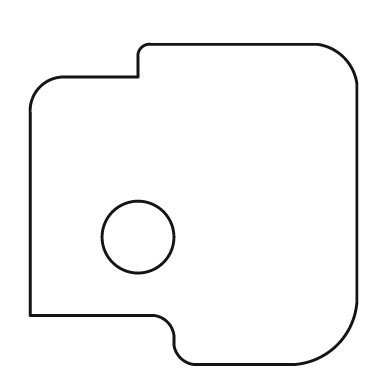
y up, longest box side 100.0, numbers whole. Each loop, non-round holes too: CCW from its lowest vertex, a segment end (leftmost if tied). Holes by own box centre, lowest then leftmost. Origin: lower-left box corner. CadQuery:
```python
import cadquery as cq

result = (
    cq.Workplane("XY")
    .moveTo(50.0, 0.0)
    .lineTo(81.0, 0.0)
    .threePointArc((94.0, 6.0), (100.0, 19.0))
    .lineTo(100.0, 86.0)
    .threePointArc((96.0, 94.0), (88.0, 98.0))
    .lineTo(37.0, 98.0)
    .threePointArc((34.0, 97.0), (33.0, 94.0))
    .lineTo(33.0, 88.0)
    .lineTo(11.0, 88.0)
    .threePointArc((3.0, 85.0), (0.0, 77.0))
    .lineTo(0.0, 15.0)
    .lineTo(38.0, 15.0)
    .threePointArc((42.0, 13.0), (44.0, 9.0))
    .lineTo(44.0, 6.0)
    .threePointArc((46.0, 2.0), (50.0, 0.0))
    .close()
    .moveTo(33.0, 39.0)
    .circle(11.0)
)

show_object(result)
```